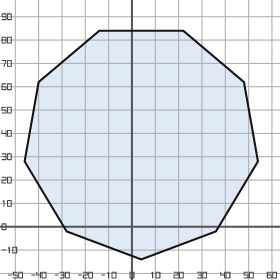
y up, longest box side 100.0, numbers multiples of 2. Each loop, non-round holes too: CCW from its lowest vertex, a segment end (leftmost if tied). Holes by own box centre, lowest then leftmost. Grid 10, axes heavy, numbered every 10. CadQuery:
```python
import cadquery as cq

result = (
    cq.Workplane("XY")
    .moveTo(4.0, -14.0)
    .lineTo(36.0, -2.0)
    .lineTo(54.0, 28.0)
    .lineTo(48.0, 62.0)
    .lineTo(22.0, 84.0)
    .lineTo(-14.0, 84.0)
    .lineTo(-40.0, 62.0)
    .lineTo(-46.0, 28.0)
    .lineTo(-28.0, -2.0)
    .close()
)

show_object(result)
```